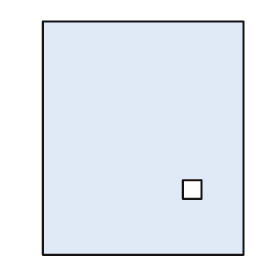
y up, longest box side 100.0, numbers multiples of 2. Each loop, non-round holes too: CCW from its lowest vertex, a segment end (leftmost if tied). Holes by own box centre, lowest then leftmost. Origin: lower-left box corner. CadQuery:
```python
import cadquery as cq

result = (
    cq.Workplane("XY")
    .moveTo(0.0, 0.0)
    .lineTo(86.0, 0.0)
    .lineTo(86.0, 100.0)
    .lineTo(0.0, 100.0)
    .close()
    .moveTo(60.0, 24.0)
    .lineTo(68.0, 24.0)
    .lineTo(68.0, 32.0)
    .lineTo(60.0, 32.0)
    .close()
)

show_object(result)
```